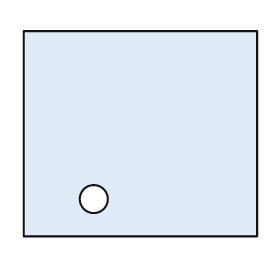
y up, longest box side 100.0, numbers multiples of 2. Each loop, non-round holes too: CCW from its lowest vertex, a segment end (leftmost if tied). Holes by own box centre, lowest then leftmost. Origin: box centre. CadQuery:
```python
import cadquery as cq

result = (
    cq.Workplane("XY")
    .moveTo(-50.0, -44.0)
    .lineTo(50.0, -44.0)
    .lineTo(50.0, 44.0)
    .lineTo(-50.0, 44.0)
    .close()
    .moveTo(-20.0, -28.0)
    .circle(6.0)
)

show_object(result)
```